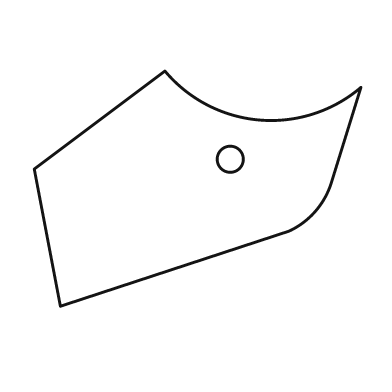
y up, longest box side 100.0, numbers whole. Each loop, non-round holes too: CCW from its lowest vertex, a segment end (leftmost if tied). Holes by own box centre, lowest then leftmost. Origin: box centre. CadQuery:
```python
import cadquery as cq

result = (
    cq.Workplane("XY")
    .moveTo(-42.0, -36.0)
    .lineTo(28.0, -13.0)
    .threePointArc((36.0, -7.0), (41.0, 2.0))
    .lineTo(50.0, 31.0)
    .threePointArc((19.0, 21.0), (-10.0, 36.0))
    .lineTo(-50.0, 6.0)
    .close()
    .moveTo(10.0, 9.0)
    .circle(4.0)
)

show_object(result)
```